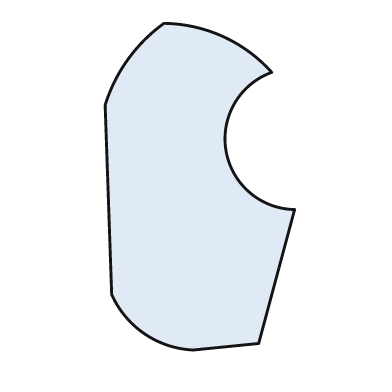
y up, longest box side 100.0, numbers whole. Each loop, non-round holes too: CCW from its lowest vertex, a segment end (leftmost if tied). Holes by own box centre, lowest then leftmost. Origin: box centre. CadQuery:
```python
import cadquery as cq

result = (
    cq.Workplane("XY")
    .moveTo(-2.0, -50.0)
    .lineTo(18.0, -48.0)
    .lineTo(29.0, -7.0)
    .threePointArc((8.0, 11.0), (22.0, 35.0))
    .threePointArc((7.0, 46.0), (-11.0, 50.0))
    .threePointArc((-22.0, 39.0), (-29.0, 25.0))
    .lineTo(-27.0, -33.0)
    .threePointArc((-17.0, -45.0), (-2.0, -50.0))
    .close()
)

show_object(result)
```